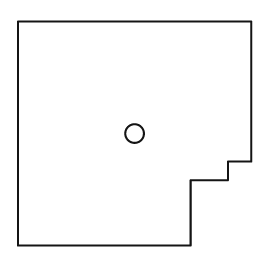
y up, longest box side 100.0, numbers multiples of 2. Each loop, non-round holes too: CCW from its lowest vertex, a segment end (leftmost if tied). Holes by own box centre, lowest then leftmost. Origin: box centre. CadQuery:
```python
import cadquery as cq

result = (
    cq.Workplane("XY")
    .moveTo(-50.0, -48.0)
    .lineTo(24.0, -48.0)
    .lineTo(24.0, -20.0)
    .lineTo(40.0, -20.0)
    .lineTo(40.0, -12.0)
    .lineTo(50.0, -12.0)
    .lineTo(50.0, 48.0)
    .lineTo(-50.0, 48.0)
    .close()
    .moveTo(0.0, 0.0)
    .circle(4.0)
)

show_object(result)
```